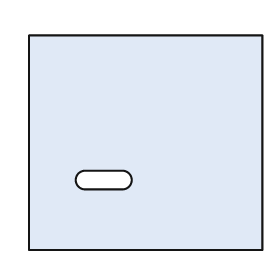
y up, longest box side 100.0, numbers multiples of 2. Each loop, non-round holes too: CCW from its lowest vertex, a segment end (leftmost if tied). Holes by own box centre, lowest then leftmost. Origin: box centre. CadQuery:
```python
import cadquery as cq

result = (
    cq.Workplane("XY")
    .moveTo(-50.0, -46.0)
    .lineTo(50.0, -46.0)
    .lineTo(50.0, 46.0)
    .lineTo(-50.0, 46.0)
    .close()
    .moveTo(-26.0, -20.0)
    .lineTo(-10.0, -20.0)
    .threePointArc((-6.0, -16.0), (-10.0, -12.0))
    .lineTo(-26.0, -12.0)
    .threePointArc((-30.0, -16.0), (-26.0, -20.0))
    .close()
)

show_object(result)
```